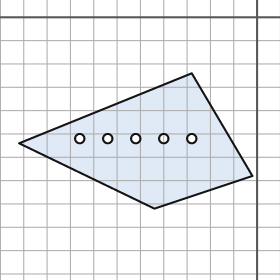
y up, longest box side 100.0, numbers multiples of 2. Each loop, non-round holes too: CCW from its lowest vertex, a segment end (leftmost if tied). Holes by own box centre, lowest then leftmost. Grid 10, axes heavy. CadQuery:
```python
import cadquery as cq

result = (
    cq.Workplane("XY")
    .moveTo(-44.0, -82.0)
    .lineTo(-2.0, -68.0)
    .lineTo(-28.0, -24.0)
    .lineTo(-102.0, -54.0)
    .close()
    .moveTo(-76.0, -52.0)
    .circle(2.0)
    .moveTo(-64.0, -52.0)
    .circle(2.0)
    .moveTo(-52.0, -52.0)
    .circle(2.0)
    .moveTo(-40.0, -52.0)
    .circle(2.0)
    .moveTo(-28.0, -52.0)
    .circle(2.0)
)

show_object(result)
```